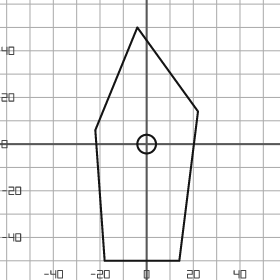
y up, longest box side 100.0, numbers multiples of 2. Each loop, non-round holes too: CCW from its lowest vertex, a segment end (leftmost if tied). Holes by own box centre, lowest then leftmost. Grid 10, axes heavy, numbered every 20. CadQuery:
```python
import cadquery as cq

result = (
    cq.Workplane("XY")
    .moveTo(-18.0, -50.0)
    .lineTo(14.0, -50.0)
    .lineTo(22.0, 14.0)
    .lineTo(-4.0, 50.0)
    .lineTo(-22.0, 6.0)
    .close()
    .moveTo(0.0, 0.0)
    .circle(4.0)
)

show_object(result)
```